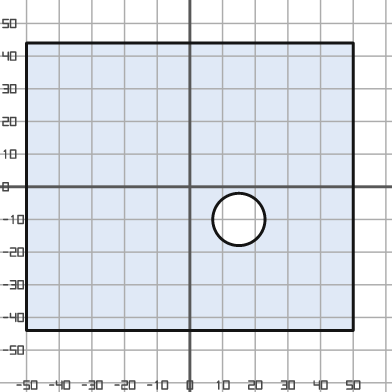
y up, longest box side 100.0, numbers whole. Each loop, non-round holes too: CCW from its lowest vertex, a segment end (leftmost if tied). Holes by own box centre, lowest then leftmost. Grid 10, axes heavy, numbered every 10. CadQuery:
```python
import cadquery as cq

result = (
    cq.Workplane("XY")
    .moveTo(-50.0, -44.0)
    .lineTo(50.0, -44.0)
    .lineTo(50.0, 44.0)
    .lineTo(-50.0, 44.0)
    .close()
    .moveTo(15.0, -10.0)
    .circle(8.0)
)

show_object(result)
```